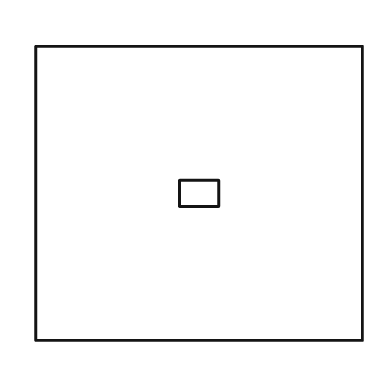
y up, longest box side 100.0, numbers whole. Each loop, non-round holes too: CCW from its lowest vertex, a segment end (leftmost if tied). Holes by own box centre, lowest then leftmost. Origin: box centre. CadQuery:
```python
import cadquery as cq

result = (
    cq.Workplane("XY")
    .moveTo(-50.0, -45.0)
    .lineTo(50.0, -45.0)
    .lineTo(50.0, 45.0)
    .lineTo(-50.0, 45.0)
    .close()
    .moveTo(-6.0, -4.0)
    .lineTo(6.0, -4.0)
    .lineTo(6.0, 4.0)
    .lineTo(-6.0, 4.0)
    .close()
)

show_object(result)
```